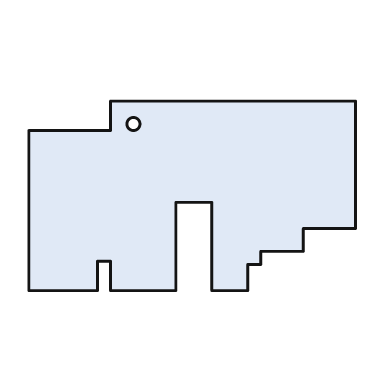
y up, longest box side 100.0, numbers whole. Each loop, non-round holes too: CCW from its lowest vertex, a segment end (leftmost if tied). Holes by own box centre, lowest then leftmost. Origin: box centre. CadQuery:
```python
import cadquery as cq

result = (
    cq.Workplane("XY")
    .moveTo(-50.0, -29.0)
    .lineTo(-29.0, -29.0)
    .lineTo(-29.0, -20.0)
    .lineTo(-25.0, -20.0)
    .lineTo(-25.0, -29.0)
    .lineTo(-5.0, -29.0)
    .lineTo(-5.0, -2.0)
    .lineTo(6.0, -2.0)
    .lineTo(6.0, -29.0)
    .lineTo(17.0, -29.0)
    .lineTo(17.0, -21.0)
    .lineTo(21.0, -21.0)
    .lineTo(21.0, -17.0)
    .lineTo(34.0, -17.0)
    .lineTo(34.0, -10.0)
    .lineTo(50.0, -10.0)
    .lineTo(50.0, 29.0)
    .lineTo(-25.0, 29.0)
    .lineTo(-25.0, 20.0)
    .lineTo(-50.0, 20.0)
    .close()
    .moveTo(-18.0, 22.0)
    .circle(2.0)
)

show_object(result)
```